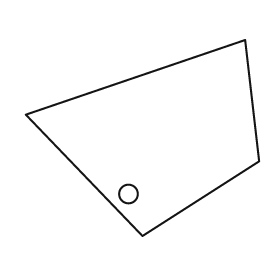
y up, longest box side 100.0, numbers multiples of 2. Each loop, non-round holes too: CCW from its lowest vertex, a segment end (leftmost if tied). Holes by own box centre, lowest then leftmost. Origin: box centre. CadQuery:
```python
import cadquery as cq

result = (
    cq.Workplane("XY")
    .moveTo(0.0, -42.0)
    .lineTo(50.0, -10.0)
    .lineTo(44.0, 42.0)
    .lineTo(-50.0, 10.0)
    .close()
    .moveTo(-6.0, -24.0)
    .circle(4.0)
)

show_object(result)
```